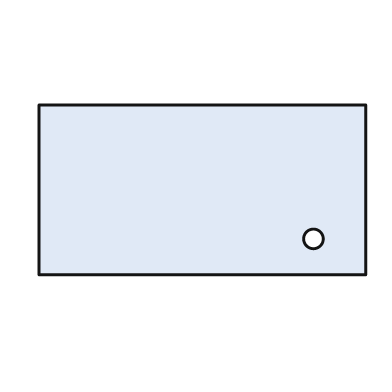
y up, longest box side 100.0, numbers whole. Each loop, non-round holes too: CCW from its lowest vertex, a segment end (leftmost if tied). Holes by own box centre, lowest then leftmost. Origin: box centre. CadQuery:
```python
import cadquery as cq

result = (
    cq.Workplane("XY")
    .moveTo(-50.0, -26.0)
    .lineTo(50.0, -26.0)
    .lineTo(50.0, 26.0)
    .lineTo(-50.0, 26.0)
    .close()
    .moveTo(34.0, -15.0)
    .circle(3.0)
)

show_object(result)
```